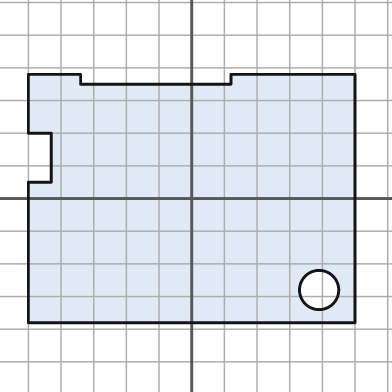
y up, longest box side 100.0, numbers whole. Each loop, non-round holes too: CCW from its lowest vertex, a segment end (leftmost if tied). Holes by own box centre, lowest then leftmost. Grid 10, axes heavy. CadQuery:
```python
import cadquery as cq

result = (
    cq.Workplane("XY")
    .moveTo(-50.0, -38.0)
    .lineTo(50.0, -38.0)
    .lineTo(50.0, 38.0)
    .lineTo(12.0, 38.0)
    .lineTo(12.0, 35.0)
    .lineTo(-34.0, 35.0)
    .lineTo(-34.0, 38.0)
    .lineTo(-50.0, 38.0)
    .lineTo(-50.0, 20.0)
    .lineTo(-43.0, 20.0)
    .lineTo(-43.0, 5.0)
    .lineTo(-50.0, 5.0)
    .close()
    .moveTo(39.0, -28.0)
    .circle(6.0)
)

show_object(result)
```